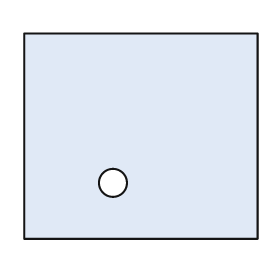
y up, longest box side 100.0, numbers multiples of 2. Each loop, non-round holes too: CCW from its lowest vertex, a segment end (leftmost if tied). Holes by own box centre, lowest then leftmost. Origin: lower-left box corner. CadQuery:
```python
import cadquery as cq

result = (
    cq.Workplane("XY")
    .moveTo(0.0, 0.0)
    .lineTo(100.0, 0.0)
    .lineTo(100.0, 88.0)
    .lineTo(0.0, 88.0)
    .close()
    .moveTo(38.0, 24.0)
    .circle(6.0)
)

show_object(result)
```